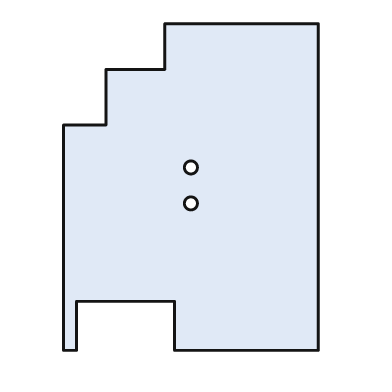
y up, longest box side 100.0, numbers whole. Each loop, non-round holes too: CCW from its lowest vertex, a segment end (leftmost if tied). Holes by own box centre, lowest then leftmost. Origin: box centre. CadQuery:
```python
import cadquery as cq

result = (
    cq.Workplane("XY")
    .moveTo(-39.0, -50.0)
    .lineTo(-35.0, -50.0)
    .lineTo(-35.0, -35.0)
    .lineTo(-5.0, -35.0)
    .lineTo(-5.0, -50.0)
    .lineTo(39.0, -50.0)
    .lineTo(39.0, 50.0)
    .lineTo(-8.0, 50.0)
    .lineTo(-8.0, 36.0)
    .lineTo(-26.0, 36.0)
    .lineTo(-26.0, 19.0)
    .lineTo(-39.0, 19.0)
    .close()
    .moveTo(0.0, -5.0)
    .circle(2.0)
    .moveTo(0.0, 6.0)
    .circle(2.0)
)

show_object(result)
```